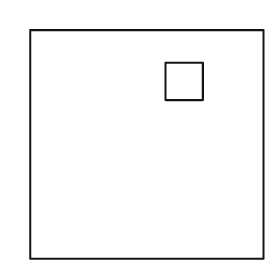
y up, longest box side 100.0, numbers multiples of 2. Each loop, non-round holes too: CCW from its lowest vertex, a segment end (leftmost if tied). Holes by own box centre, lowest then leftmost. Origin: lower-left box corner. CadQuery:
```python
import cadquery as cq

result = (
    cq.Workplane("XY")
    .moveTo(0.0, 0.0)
    .lineTo(100.0, 0.0)
    .lineTo(100.0, 98.0)
    .lineTo(0.0, 98.0)
    .close()
    .moveTo(58.0, 68.0)
    .lineTo(74.0, 68.0)
    .lineTo(74.0, 84.0)
    .lineTo(58.0, 84.0)
    .close()
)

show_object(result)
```